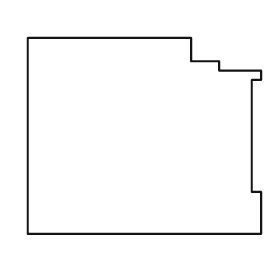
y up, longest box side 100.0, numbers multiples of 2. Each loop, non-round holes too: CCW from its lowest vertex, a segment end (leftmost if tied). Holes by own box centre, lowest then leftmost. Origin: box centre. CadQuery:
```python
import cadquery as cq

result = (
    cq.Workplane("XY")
    .moveTo(-50.0, -42.0)
    .lineTo(50.0, -42.0)
    .lineTo(50.0, -24.0)
    .lineTo(46.0, -24.0)
    .lineTo(46.0, 24.0)
    .lineTo(50.0, 24.0)
    .lineTo(50.0, 28.0)
    .lineTo(32.0, 28.0)
    .lineTo(32.0, 32.0)
    .lineTo(20.0, 32.0)
    .lineTo(20.0, 42.0)
    .lineTo(-50.0, 42.0)
    .close()
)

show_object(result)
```